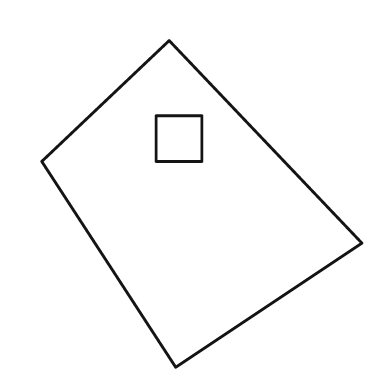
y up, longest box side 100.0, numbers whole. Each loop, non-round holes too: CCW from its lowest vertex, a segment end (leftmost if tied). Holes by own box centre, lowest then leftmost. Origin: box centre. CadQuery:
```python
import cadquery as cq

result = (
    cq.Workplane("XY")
    .moveTo(-8.0, -50.0)
    .lineTo(49.0, -12.0)
    .lineTo(-10.0, 50.0)
    .lineTo(-49.0, 13.0)
    .close()
    .moveTo(-14.0, 13.0)
    .lineTo(0.0, 13.0)
    .lineTo(0.0, 27.0)
    .lineTo(-14.0, 27.0)
    .close()
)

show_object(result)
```